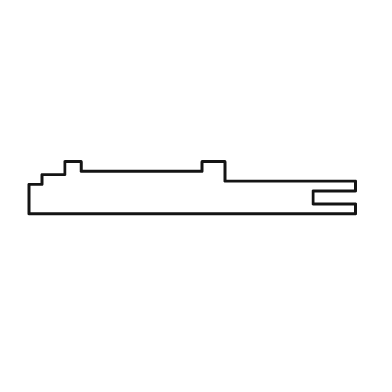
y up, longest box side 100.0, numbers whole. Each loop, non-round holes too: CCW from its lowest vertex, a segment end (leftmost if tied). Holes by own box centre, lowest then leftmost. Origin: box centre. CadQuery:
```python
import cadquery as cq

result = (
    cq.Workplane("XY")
    .moveTo(-50.0, -8.0)
    .lineTo(50.0, -8.0)
    .lineTo(50.0, -5.0)
    .lineTo(37.0, -5.0)
    .lineTo(37.0, -1.0)
    .lineTo(50.0, -1.0)
    .lineTo(50.0, 2.0)
    .lineTo(10.0, 2.0)
    .lineTo(10.0, 8.0)
    .lineTo(3.0, 8.0)
    .lineTo(3.0, 5.0)
    .lineTo(-34.0, 5.0)
    .lineTo(-34.0, 8.0)
    .lineTo(-39.0, 8.0)
    .lineTo(-39.0, 4.0)
    .lineTo(-46.0, 4.0)
    .lineTo(-46.0, 1.0)
    .lineTo(-50.0, 1.0)
    .close()
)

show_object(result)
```